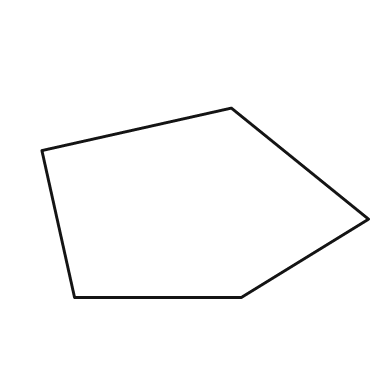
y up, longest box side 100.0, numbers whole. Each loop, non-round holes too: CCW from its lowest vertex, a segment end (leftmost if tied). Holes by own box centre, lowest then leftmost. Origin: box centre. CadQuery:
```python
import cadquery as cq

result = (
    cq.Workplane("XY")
    .moveTo(-40.0, -29.0)
    .lineTo(11.0, -29.0)
    .lineTo(50.0, -5.0)
    .lineTo(8.0, 29.0)
    .lineTo(-50.0, 16.0)
    .close()
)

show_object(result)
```